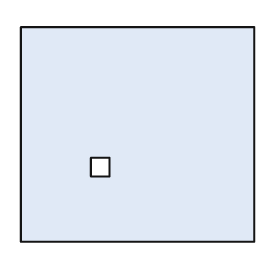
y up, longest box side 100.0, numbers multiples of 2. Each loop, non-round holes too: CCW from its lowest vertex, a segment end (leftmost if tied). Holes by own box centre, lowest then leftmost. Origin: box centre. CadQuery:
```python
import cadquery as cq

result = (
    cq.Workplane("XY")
    .moveTo(-50.0, -46.0)
    .lineTo(50.0, -46.0)
    .lineTo(50.0, 46.0)
    .lineTo(-50.0, 46.0)
    .close()
    .moveTo(-20.0, -18.0)
    .lineTo(-12.0, -18.0)
    .lineTo(-12.0, -10.0)
    .lineTo(-20.0, -10.0)
    .close()
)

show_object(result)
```